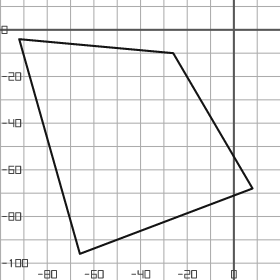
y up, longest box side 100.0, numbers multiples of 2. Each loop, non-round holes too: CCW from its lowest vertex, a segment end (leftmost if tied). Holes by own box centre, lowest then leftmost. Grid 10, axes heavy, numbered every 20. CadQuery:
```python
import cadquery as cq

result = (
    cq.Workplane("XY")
    .moveTo(-66.0, -96.0)
    .lineTo(8.0, -68.0)
    .lineTo(-26.0, -10.0)
    .lineTo(-92.0, -4.0)
    .close()
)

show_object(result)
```